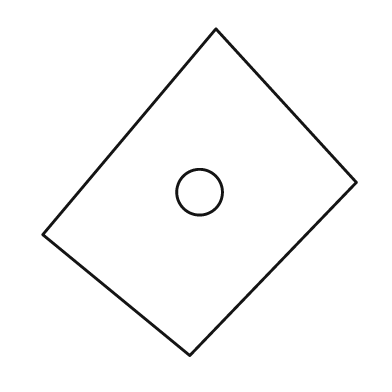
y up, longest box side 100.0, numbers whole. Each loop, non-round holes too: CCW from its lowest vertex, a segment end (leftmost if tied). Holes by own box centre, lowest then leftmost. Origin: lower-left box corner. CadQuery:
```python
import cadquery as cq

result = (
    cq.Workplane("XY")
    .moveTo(45.0, 0.0)
    .lineTo(96.0, 53.0)
    .lineTo(53.0, 100.0)
    .lineTo(0.0, 37.0)
    .close()
    .moveTo(48.0, 50.0)
    .circle(7.0)
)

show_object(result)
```